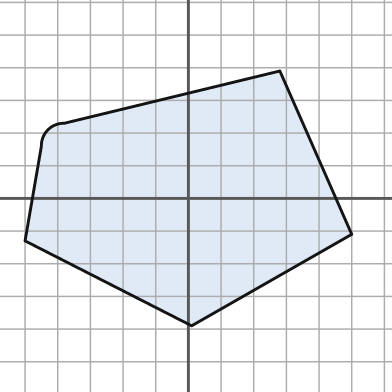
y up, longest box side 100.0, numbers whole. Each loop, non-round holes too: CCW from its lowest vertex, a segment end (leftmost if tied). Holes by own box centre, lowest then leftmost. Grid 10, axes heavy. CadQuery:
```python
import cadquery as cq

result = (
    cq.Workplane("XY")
    .moveTo(1.0, -39.0)
    .lineTo(50.0, -11.0)
    .lineTo(28.0, 39.0)
    .lineTo(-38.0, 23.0)
    .threePointArc((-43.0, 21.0), (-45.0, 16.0))
    .lineTo(-50.0, -13.0)
    .close()
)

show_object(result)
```